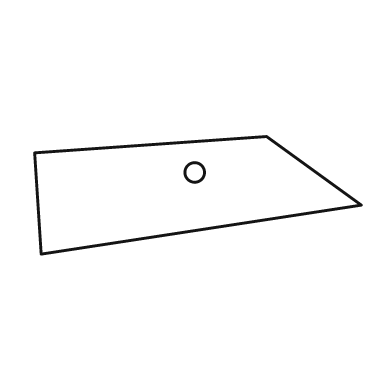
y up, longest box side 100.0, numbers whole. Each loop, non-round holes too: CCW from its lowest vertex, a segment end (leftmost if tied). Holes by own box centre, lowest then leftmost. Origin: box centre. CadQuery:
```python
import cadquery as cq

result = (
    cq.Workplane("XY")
    .moveTo(-48.0, -18.0)
    .lineTo(50.0, -3.0)
    .lineTo(21.0, 18.0)
    .lineTo(-50.0, 13.0)
    .close()
    .moveTo(-1.0, 7.0)
    .circle(3.0)
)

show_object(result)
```